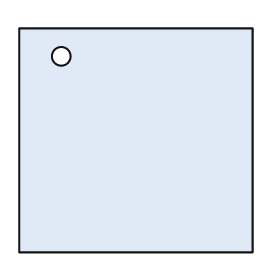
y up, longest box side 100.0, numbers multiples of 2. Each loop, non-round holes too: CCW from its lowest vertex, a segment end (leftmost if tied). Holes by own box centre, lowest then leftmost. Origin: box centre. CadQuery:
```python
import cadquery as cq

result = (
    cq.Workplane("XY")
    .moveTo(-50.0, -48.0)
    .lineTo(50.0, -48.0)
    .lineTo(50.0, 48.0)
    .lineTo(-50.0, 48.0)
    .close()
    .moveTo(-32.0, 36.0)
    .circle(4.0)
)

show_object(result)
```